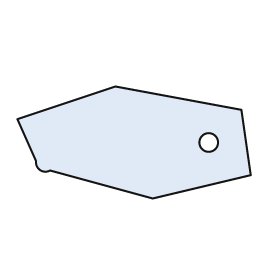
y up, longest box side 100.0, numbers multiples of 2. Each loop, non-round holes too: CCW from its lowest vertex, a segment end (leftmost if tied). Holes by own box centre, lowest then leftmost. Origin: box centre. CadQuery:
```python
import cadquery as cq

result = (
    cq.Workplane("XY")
    .moveTo(8.0, -24.0)
    .lineTo(50.0, -14.0)
    .lineTo(46.0, 14.0)
    .lineTo(-8.0, 24.0)
    .lineTo(-50.0, 10.0)
    .lineTo(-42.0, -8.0)
    .threePointArc((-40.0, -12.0), (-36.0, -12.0))
    .close()
    .moveTo(32.0, 0.0)
    .circle(4.0)
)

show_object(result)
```